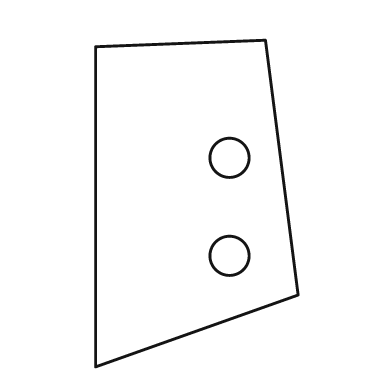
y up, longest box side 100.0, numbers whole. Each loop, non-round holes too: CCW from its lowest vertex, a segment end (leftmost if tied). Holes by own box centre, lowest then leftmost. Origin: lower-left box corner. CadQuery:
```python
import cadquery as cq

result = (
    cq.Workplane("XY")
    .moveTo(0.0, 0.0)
    .lineTo(62.0, 22.0)
    .lineTo(52.0, 100.0)
    .lineTo(0.0, 98.0)
    .close()
    .moveTo(41.0, 34.0)
    .circle(6.0)
    .moveTo(41.0, 64.0)
    .circle(6.0)
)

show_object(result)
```